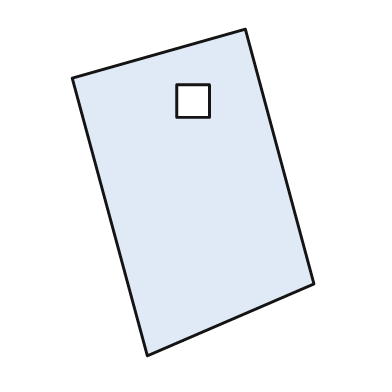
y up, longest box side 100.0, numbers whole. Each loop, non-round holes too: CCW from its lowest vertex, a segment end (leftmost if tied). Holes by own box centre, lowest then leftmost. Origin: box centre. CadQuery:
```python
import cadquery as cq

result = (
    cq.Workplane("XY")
    .moveTo(-14.0, -50.0)
    .lineTo(37.0, -28.0)
    .lineTo(16.0, 50.0)
    .lineTo(-37.0, 35.0)
    .close()
    .moveTo(-5.0, 23.0)
    .lineTo(5.0, 23.0)
    .lineTo(5.0, 33.0)
    .lineTo(-5.0, 33.0)
    .close()
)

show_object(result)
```